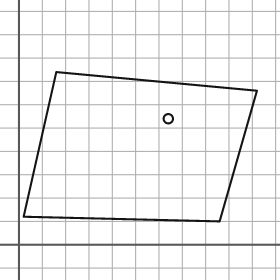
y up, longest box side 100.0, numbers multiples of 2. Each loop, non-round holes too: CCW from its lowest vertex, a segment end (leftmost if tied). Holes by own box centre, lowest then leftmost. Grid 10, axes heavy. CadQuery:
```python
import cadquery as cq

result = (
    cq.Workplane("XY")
    .moveTo(86.0, 10.0)
    .lineTo(102.0, 66.0)
    .lineTo(16.0, 74.0)
    .lineTo(2.0, 12.0)
    .close()
    .moveTo(64.0, 54.0)
    .circle(2.0)
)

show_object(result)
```